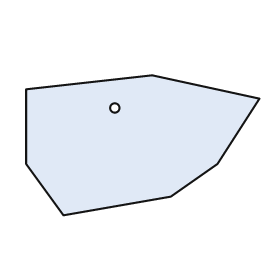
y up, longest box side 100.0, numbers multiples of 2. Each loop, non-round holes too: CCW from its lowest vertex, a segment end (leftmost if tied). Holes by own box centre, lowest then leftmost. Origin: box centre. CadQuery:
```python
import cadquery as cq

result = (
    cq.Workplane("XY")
    .moveTo(-34.0, -30.0)
    .lineTo(12.0, -22.0)
    .lineTo(32.0, -8.0)
    .lineTo(50.0, 20.0)
    .lineTo(4.0, 30.0)
    .lineTo(-50.0, 24.0)
    .lineTo(-50.0, -8.0)
    .close()
    .moveTo(-12.0, 16.0)
    .circle(2.0)
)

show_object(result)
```